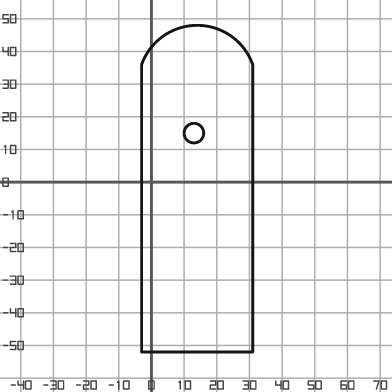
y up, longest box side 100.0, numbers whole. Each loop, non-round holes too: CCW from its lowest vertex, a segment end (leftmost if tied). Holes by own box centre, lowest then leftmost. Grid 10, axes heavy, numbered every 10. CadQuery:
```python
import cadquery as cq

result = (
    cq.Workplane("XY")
    .moveTo(-3.0, -52.0)
    .lineTo(31.0, -52.0)
    .lineTo(31.0, 36.0)
    .threePointArc((14.0, 48.0), (-3.0, 36.0))
    .close()
    .moveTo(13.0, 15.0)
    .circle(3.0)
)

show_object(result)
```